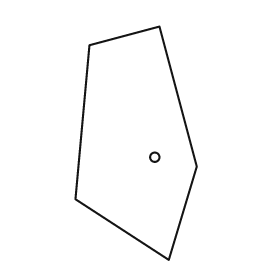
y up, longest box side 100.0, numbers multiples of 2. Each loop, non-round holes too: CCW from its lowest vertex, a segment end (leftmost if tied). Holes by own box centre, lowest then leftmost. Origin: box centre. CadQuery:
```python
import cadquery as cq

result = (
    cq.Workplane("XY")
    .moveTo(14.0, -50.0)
    .lineTo(26.0, -10.0)
    .lineTo(10.0, 50.0)
    .lineTo(-20.0, 42.0)
    .lineTo(-26.0, -24.0)
    .close()
    .moveTo(8.0, -6.0)
    .circle(2.0)
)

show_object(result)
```